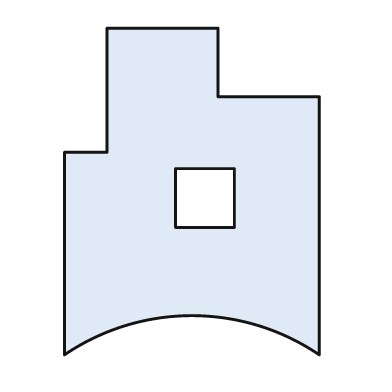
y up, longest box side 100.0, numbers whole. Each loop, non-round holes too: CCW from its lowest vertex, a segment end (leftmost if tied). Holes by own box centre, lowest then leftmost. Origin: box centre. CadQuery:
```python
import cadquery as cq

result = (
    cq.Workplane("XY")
    .moveTo(-39.0, -50.0)
    .threePointArc((0.0, -38.0), (39.0, -50.0))
    .lineTo(39.0, 29.0)
    .lineTo(8.0, 29.0)
    .lineTo(8.0, 50.0)
    .lineTo(-26.0, 50.0)
    .lineTo(-26.0, 12.0)
    .lineTo(-39.0, 12.0)
    .close()
    .moveTo(-5.0, -11.0)
    .lineTo(13.0, -11.0)
    .lineTo(13.0, 7.0)
    .lineTo(-5.0, 7.0)
    .close()
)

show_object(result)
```